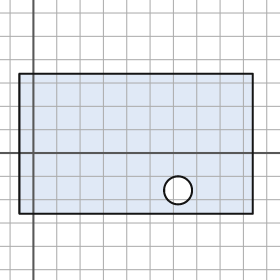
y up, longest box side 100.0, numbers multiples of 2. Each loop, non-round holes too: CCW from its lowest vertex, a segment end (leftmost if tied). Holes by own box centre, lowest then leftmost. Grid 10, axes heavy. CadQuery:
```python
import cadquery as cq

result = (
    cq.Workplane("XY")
    .moveTo(-6.0, -26.0)
    .lineTo(94.0, -26.0)
    .lineTo(94.0, 34.0)
    .lineTo(-6.0, 34.0)
    .close()
    .moveTo(62.0, -16.0)
    .circle(6.0)
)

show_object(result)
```